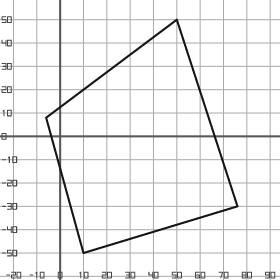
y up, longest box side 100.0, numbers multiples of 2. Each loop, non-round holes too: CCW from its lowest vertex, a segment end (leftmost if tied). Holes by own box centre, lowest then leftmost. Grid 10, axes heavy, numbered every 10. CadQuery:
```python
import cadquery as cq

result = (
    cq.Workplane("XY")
    .moveTo(10.0, -50.0)
    .lineTo(76.0, -30.0)
    .lineTo(50.0, 50.0)
    .lineTo(-6.0, 8.0)
    .close()
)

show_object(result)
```